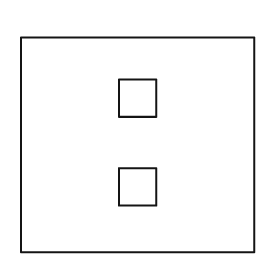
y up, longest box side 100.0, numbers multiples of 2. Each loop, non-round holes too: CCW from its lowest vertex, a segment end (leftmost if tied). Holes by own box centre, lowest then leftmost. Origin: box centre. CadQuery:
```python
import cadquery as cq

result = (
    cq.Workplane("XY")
    .moveTo(-50.0, -46.0)
    .lineTo(50.0, -46.0)
    .lineTo(50.0, 46.0)
    .lineTo(-50.0, 46.0)
    .close()
    .moveTo(-8.0, -26.0)
    .lineTo(8.0, -26.0)
    .lineTo(8.0, -10.0)
    .lineTo(-8.0, -10.0)
    .close()
    .moveTo(-8.0, 12.0)
    .lineTo(8.0, 12.0)
    .lineTo(8.0, 28.0)
    .lineTo(-8.0, 28.0)
    .close()
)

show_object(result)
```